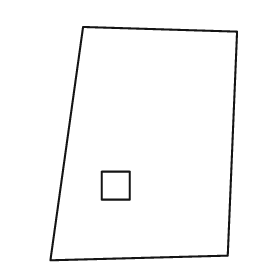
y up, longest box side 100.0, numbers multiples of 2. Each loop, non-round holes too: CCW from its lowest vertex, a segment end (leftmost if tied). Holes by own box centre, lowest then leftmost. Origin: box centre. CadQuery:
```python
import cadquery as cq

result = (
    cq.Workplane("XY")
    .moveTo(-40.0, -50.0)
    .lineTo(36.0, -48.0)
    .lineTo(40.0, 48.0)
    .lineTo(-26.0, 50.0)
    .close()
    .moveTo(-18.0, -24.0)
    .lineTo(-6.0, -24.0)
    .lineTo(-6.0, -12.0)
    .lineTo(-18.0, -12.0)
    .close()
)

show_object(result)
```